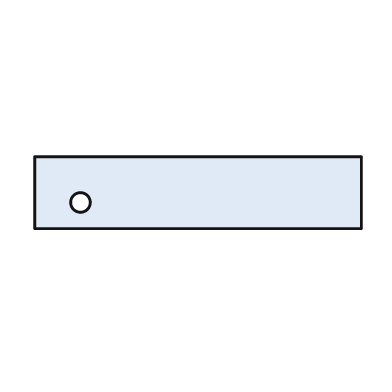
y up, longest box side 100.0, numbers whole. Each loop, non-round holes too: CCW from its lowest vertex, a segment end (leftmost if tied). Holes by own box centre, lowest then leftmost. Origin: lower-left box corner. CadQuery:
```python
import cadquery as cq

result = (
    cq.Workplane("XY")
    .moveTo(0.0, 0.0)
    .lineTo(100.0, 0.0)
    .lineTo(100.0, 22.0)
    .lineTo(0.0, 22.0)
    .close()
    .moveTo(14.0, 8.0)
    .circle(3.0)
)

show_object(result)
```